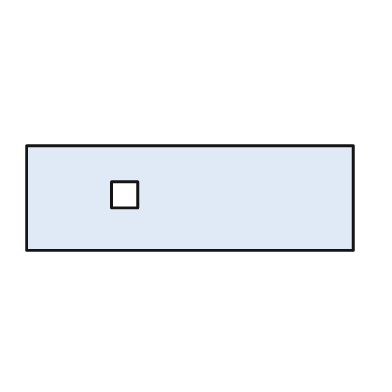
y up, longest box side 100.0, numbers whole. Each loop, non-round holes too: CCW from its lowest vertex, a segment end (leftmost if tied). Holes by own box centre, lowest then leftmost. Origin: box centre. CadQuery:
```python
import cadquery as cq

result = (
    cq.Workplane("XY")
    .moveTo(-50.0, -16.0)
    .lineTo(50.0, -16.0)
    .lineTo(50.0, 16.0)
    .lineTo(-50.0, 16.0)
    .close()
    .moveTo(-24.0, -3.0)
    .lineTo(-16.0, -3.0)
    .lineTo(-16.0, 5.0)
    .lineTo(-24.0, 5.0)
    .close()
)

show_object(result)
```